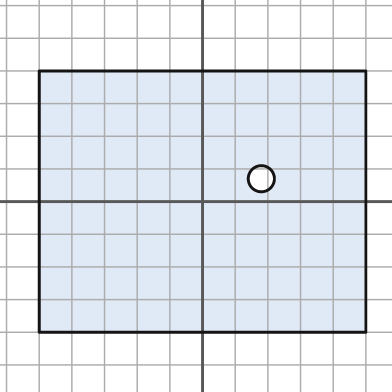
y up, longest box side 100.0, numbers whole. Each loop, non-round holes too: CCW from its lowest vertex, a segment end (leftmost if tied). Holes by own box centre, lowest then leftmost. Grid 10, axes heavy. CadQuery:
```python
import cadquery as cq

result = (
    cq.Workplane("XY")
    .moveTo(-50.0, -40.0)
    .lineTo(50.0, -40.0)
    .lineTo(50.0, 40.0)
    .lineTo(-50.0, 40.0)
    .close()
    .moveTo(18.0, 7.0)
    .circle(4.0)
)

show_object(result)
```